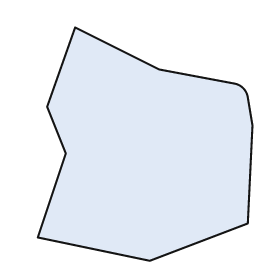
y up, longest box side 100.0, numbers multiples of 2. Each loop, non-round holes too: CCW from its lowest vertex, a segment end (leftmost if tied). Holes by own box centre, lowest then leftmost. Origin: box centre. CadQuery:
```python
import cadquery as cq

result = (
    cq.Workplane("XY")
    .moveTo(2.0, -50.0)
    .lineTo(44.0, -34.0)
    .lineTo(46.0, 8.0)
    .lineTo(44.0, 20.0)
    .threePointArc((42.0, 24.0), (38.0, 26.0))
    .lineTo(6.0, 32.0)
    .lineTo(-30.0, 50.0)
    .lineTo(-42.0, 16.0)
    .lineTo(-34.0, -4.0)
    .lineTo(-46.0, -40.0)
    .close()
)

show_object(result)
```